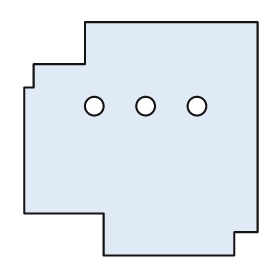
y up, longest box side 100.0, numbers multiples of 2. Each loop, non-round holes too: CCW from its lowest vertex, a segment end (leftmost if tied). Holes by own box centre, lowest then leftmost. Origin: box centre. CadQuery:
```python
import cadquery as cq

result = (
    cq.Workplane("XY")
    .moveTo(-16.0, -50.0)
    .lineTo(40.0, -50.0)
    .lineTo(40.0, -40.0)
    .lineTo(50.0, -40.0)
    .lineTo(50.0, 50.0)
    .lineTo(-24.0, 50.0)
    .lineTo(-24.0, 32.0)
    .lineTo(-46.0, 32.0)
    .lineTo(-46.0, 22.0)
    .lineTo(-50.0, 22.0)
    .lineTo(-50.0, -32.0)
    .lineTo(-16.0, -32.0)
    .close()
    .moveTo(-20.0, 14.0)
    .circle(4.0)
    .moveTo(2.0, 14.0)
    .circle(4.0)
    .moveTo(24.0, 14.0)
    .circle(4.0)
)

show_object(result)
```